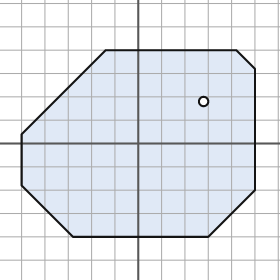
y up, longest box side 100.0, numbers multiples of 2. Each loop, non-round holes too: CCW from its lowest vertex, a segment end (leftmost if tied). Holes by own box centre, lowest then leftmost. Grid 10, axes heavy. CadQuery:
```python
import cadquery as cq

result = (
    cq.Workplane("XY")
    .moveTo(-28.0, -40.0)
    .lineTo(30.0, -40.0)
    .lineTo(50.0, -20.0)
    .lineTo(50.0, 32.0)
    .lineTo(42.0, 40.0)
    .lineTo(-14.0, 40.0)
    .lineTo(-50.0, 4.0)
    .lineTo(-50.0, -18.0)
    .close()
    .moveTo(28.0, 18.0)
    .circle(2.0)
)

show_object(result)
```